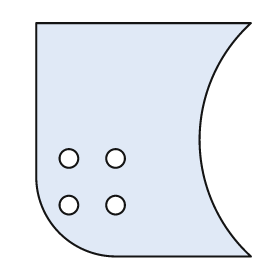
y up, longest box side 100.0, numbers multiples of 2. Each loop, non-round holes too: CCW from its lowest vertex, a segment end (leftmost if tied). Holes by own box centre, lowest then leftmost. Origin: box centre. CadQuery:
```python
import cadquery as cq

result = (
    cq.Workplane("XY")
    .moveTo(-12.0, -50.0)
    .lineTo(46.0, -50.0)
    .threePointArc((24.0, 0.0), (46.0, 50.0))
    .lineTo(-46.0, 50.0)
    .lineTo(-46.0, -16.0)
    .threePointArc((-36.0, -40.0), (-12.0, -50.0))
    .close()
    .moveTo(-32.0, -28.0)
    .circle(4.0)
    .moveTo(-12.0, -28.0)
    .circle(4.0)
    .moveTo(-32.0, -8.0)
    .circle(4.0)
    .moveTo(-12.0, -8.0)
    .circle(4.0)
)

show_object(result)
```